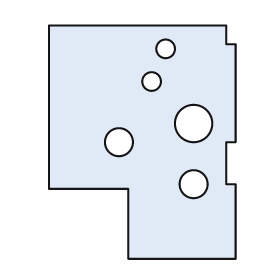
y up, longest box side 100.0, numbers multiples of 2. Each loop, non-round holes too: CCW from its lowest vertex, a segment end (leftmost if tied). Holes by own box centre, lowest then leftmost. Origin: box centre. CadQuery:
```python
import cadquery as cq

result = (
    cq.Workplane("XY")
    .moveTo(-6.0, -50.0)
    .lineTo(40.0, -50.0)
    .lineTo(40.0, -18.0)
    .lineTo(36.0, -18.0)
    .lineTo(36.0, 0.0)
    .lineTo(40.0, 0.0)
    .lineTo(40.0, 42.0)
    .lineTo(36.0, 42.0)
    .lineTo(36.0, 50.0)
    .lineTo(-40.0, 50.0)
    .lineTo(-40.0, -20.0)
    .lineTo(-6.0, -20.0)
    .close()
    .moveTo(22.0, -18.0)
    .circle(6.0)
    .moveTo(-10.0, 0.0)
    .circle(6.0)
    .moveTo(22.0, 8.0)
    .circle(8.0)
    .moveTo(4.0, 26.0)
    .circle(4.0)
    .moveTo(10.0, 40.0)
    .circle(4.0)
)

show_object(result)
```